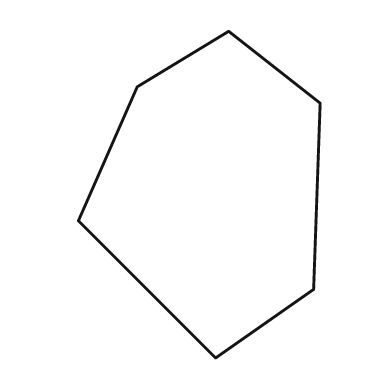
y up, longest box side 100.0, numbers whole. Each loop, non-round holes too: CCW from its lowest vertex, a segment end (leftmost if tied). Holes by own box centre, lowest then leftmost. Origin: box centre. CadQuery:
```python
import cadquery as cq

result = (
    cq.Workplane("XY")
    .moveTo(5.0, -50.0)
    .lineTo(35.0, -29.0)
    .lineTo(37.0, 28.0)
    .lineTo(9.0, 50.0)
    .lineTo(-19.0, 33.0)
    .lineTo(-37.0, -8.0)
    .close()
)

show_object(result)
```